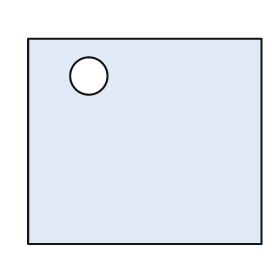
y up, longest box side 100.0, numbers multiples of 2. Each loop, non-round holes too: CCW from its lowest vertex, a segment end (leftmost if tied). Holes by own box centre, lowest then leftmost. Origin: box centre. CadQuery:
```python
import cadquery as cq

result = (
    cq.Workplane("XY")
    .moveTo(-50.0, -44.0)
    .lineTo(50.0, -44.0)
    .lineTo(50.0, 44.0)
    .lineTo(-50.0, 44.0)
    .close()
    .moveTo(-24.0, 28.0)
    .circle(8.0)
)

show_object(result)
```